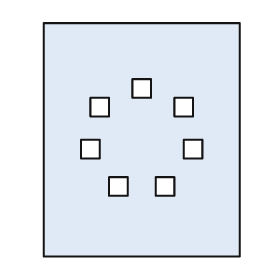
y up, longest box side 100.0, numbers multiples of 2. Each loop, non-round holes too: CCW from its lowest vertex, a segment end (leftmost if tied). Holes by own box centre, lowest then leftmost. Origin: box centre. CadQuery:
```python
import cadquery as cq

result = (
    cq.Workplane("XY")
    .moveTo(-42.0, -50.0)
    .lineTo(42.0, -50.0)
    .lineTo(42.0, 50.0)
    .lineTo(-42.0, 50.0)
    .close()
    .moveTo(-14.0, -24.0)
    .lineTo(-6.0, -24.0)
    .lineTo(-6.0, -16.0)
    .lineTo(-14.0, -16.0)
    .close()
    .moveTo(6.0, -24.0)
    .lineTo(14.0, -24.0)
    .lineTo(14.0, -16.0)
    .lineTo(6.0, -16.0)
    .close()
    .moveTo(-26.0, -8.0)
    .lineTo(-18.0, -8.0)
    .lineTo(-18.0, 0.0)
    .lineTo(-26.0, 0.0)
    .close()
    .moveTo(18.0, -8.0)
    .lineTo(26.0, -8.0)
    .lineTo(26.0, 0.0)
    .lineTo(18.0, 0.0)
    .close()
    .moveTo(-22.0, 10.0)
    .lineTo(-14.0, 10.0)
    .lineTo(-14.0, 18.0)
    .lineTo(-22.0, 18.0)
    .close()
    .moveTo(14.0, 10.0)
    .lineTo(22.0, 10.0)
    .lineTo(22.0, 18.0)
    .lineTo(14.0, 18.0)
    .close()
    .moveTo(-4.0, 18.0)
    .lineTo(4.0, 18.0)
    .lineTo(4.0, 26.0)
    .lineTo(-4.0, 26.0)
    .close()
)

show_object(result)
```